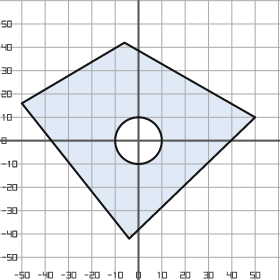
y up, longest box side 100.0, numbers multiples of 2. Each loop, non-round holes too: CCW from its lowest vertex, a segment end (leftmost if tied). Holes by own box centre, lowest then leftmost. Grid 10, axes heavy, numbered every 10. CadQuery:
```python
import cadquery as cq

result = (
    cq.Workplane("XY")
    .moveTo(-4.0, -42.0)
    .lineTo(50.0, 10.0)
    .lineTo(-6.0, 42.0)
    .lineTo(-50.0, 16.0)
    .close()
    .moveTo(0.0, 0.0)
    .circle(10.0)
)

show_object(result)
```